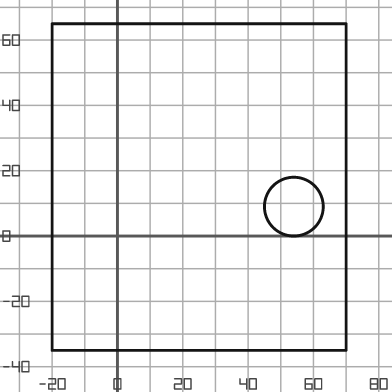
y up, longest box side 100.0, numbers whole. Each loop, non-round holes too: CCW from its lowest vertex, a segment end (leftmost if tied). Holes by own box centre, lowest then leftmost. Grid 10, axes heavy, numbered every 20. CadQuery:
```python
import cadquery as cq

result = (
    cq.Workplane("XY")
    .moveTo(-20.0, -35.0)
    .lineTo(70.0, -35.0)
    .lineTo(70.0, 65.0)
    .lineTo(-20.0, 65.0)
    .close()
    .moveTo(54.0, 9.0)
    .circle(9.0)
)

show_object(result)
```